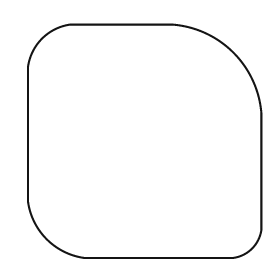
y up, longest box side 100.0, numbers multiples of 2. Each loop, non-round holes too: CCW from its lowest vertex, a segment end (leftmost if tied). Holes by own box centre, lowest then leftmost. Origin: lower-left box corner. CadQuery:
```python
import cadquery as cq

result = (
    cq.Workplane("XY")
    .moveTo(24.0, 0.0)
    .lineTo(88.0, 0.0)
    .threePointArc((96.0, 4.0), (100.0, 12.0))
    .lineTo(100.0, 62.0)
    .threePointArc((88.0, 88.0), (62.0, 100.0))
    .lineTo(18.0, 100.0)
    .threePointArc((6.0, 94.0), (0.0, 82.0))
    .lineTo(0.0, 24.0)
    .threePointArc((8.0, 8.0), (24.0, 0.0))
    .close()
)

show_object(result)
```